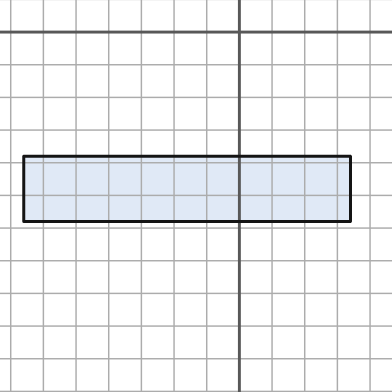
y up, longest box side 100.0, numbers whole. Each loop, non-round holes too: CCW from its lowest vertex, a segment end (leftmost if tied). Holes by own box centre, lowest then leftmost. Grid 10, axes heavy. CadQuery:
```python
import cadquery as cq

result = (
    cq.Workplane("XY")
    .moveTo(-66.0, -58.0)
    .lineTo(34.0, -58.0)
    .lineTo(34.0, -38.0)
    .lineTo(-66.0, -38.0)
    .close()
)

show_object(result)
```